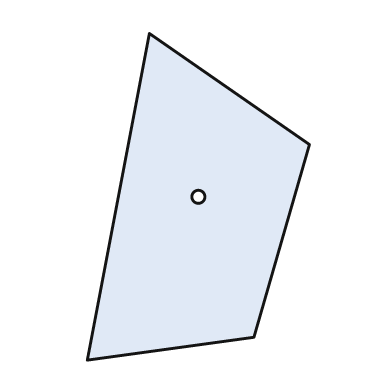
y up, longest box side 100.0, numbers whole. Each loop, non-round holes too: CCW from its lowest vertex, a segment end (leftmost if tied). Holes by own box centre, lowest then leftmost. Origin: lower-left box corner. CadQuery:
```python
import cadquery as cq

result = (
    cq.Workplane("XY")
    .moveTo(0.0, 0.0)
    .lineTo(51.0, 7.0)
    .lineTo(68.0, 66.0)
    .lineTo(19.0, 100.0)
    .close()
    .moveTo(34.0, 50.0)
    .circle(2.0)
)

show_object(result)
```